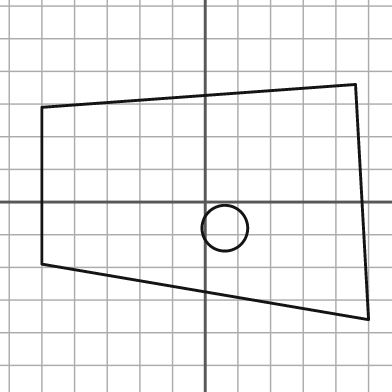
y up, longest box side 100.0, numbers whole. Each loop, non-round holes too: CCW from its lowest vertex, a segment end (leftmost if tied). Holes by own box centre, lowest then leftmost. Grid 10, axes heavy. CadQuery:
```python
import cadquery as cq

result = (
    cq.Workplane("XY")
    .moveTo(50.0, -36.0)
    .lineTo(46.0, 36.0)
    .lineTo(-50.0, 29.0)
    .lineTo(-50.0, -19.0)
    .close()
    .moveTo(6.0, -8.0)
    .circle(7.0)
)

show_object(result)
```